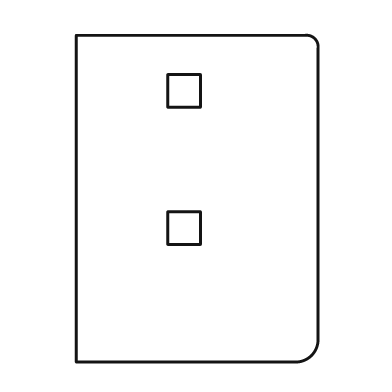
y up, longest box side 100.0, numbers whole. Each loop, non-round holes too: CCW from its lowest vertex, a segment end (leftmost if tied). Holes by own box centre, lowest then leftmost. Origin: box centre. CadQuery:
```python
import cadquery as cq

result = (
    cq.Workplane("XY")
    .moveTo(-37.0, -50.0)
    .lineTo(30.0, -50.0)
    .threePointArc((35.0, -48.0), (37.0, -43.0))
    .lineTo(37.0, 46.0)
    .threePointArc((36.0, 49.0), (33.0, 50.0))
    .lineTo(-37.0, 50.0)
    .close()
    .moveTo(-9.0, -14.0)
    .lineTo(1.0, -14.0)
    .lineTo(1.0, -4.0)
    .lineTo(-9.0, -4.0)
    .close()
    .moveTo(-9.0, 28.0)
    .lineTo(1.0, 28.0)
    .lineTo(1.0, 38.0)
    .lineTo(-9.0, 38.0)
    .close()
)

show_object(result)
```